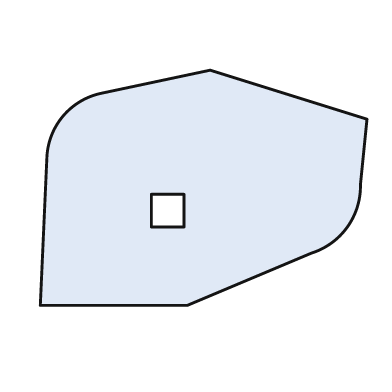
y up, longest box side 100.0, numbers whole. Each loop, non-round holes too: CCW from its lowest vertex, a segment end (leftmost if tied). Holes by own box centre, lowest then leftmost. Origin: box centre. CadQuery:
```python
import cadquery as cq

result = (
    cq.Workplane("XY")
    .moveTo(-50.0, -36.0)
    .lineTo(-5.0, -36.0)
    .lineTo(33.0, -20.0)
    .threePointArc((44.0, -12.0), (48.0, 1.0))
    .lineTo(50.0, 21.0)
    .lineTo(2.0, 36.0)
    .lineTo(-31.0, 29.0)
    .threePointArc((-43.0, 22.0), (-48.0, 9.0))
    .close()
    .moveTo(-16.0, -12.0)
    .lineTo(-6.0, -12.0)
    .lineTo(-6.0, -2.0)
    .lineTo(-16.0, -2.0)
    .close()
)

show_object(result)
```